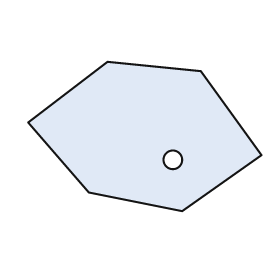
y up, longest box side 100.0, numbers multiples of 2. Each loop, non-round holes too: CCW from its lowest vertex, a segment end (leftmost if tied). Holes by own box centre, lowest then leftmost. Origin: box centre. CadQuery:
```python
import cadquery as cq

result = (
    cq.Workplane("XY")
    .moveTo(16.0, -32.0)
    .lineTo(50.0, -8.0)
    .lineTo(24.0, 28.0)
    .lineTo(-16.0, 32.0)
    .lineTo(-50.0, 6.0)
    .lineTo(-24.0, -24.0)
    .close()
    .moveTo(12.0, -10.0)
    .circle(4.0)
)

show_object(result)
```